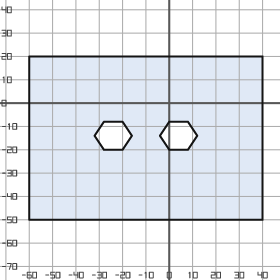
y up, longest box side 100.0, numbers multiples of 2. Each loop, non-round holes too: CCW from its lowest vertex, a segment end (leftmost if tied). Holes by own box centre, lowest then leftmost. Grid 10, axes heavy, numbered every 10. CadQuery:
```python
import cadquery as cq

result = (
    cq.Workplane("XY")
    .moveTo(-60.0, -50.0)
    .lineTo(40.0, -50.0)
    .lineTo(40.0, 20.0)
    .lineTo(-60.0, 20.0)
    .close()
    .moveTo(-28.0, -20.0)
    .lineTo(-20.0, -20.0)
    .lineTo(-16.0, -14.0)
    .lineTo(-20.0, -8.0)
    .lineTo(-28.0, -8.0)
    .lineTo(-32.0, -14.0)
    .close()
    .moveTo(0.0, -20.0)
    .lineTo(8.0, -20.0)
    .lineTo(12.0, -14.0)
    .lineTo(8.0, -8.0)
    .lineTo(0.0, -8.0)
    .lineTo(-4.0, -14.0)
    .close()
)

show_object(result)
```